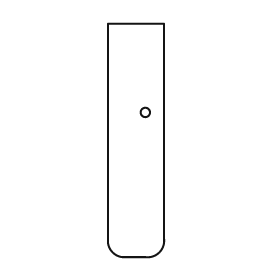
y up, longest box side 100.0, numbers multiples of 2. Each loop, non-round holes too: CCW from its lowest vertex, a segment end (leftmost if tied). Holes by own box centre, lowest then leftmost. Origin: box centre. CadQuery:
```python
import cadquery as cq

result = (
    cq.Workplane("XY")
    .moveTo(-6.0, -50.0)
    .lineTo(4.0, -50.0)
    .threePointArc((10.0, -48.0), (12.0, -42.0))
    .lineTo(12.0, 50.0)
    .lineTo(-12.0, 50.0)
    .lineTo(-12.0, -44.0)
    .threePointArc((-10.0, -48.0), (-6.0, -50.0))
    .close()
    .moveTo(4.0, 12.0)
    .circle(2.0)
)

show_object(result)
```